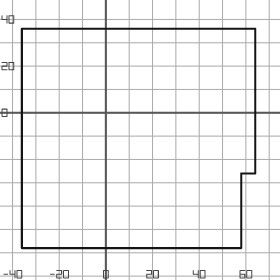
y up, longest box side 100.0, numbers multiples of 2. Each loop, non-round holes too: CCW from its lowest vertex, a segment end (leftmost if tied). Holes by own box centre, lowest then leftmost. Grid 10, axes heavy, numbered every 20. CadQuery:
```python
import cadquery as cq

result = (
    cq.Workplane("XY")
    .moveTo(-36.0, -58.0)
    .lineTo(58.0, -58.0)
    .lineTo(58.0, -26.0)
    .lineTo(64.0, -26.0)
    .lineTo(64.0, 36.0)
    .lineTo(-36.0, 36.0)
    .close()
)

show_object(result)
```